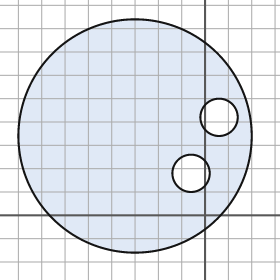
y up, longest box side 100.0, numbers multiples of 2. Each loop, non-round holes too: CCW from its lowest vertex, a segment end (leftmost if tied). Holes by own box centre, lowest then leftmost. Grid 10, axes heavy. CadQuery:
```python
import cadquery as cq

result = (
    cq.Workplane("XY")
    .moveTo(-30.0, 34.0)
    .circle(50.0)
    .moveTo(-6.0, 18.0)
    .circle(8.0)
    .moveTo(6.0, 42.0)
    .circle(8.0)
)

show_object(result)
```